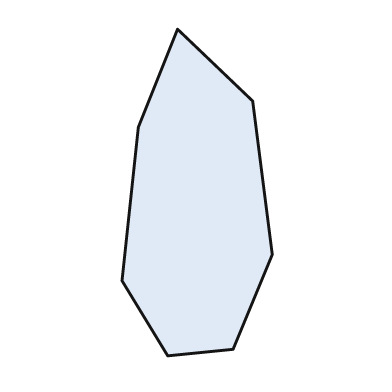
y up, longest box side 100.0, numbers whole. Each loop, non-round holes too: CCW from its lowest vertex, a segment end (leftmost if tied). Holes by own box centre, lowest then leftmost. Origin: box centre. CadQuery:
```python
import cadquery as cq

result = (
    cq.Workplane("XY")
    .moveTo(-9.0, -50.0)
    .lineTo(11.0, -48.0)
    .lineTo(23.0, -19.0)
    .lineTo(17.0, 28.0)
    .lineTo(-6.0, 50.0)
    .lineTo(-18.0, 20.0)
    .lineTo(-23.0, -27.0)
    .close()
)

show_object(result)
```